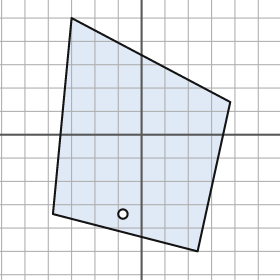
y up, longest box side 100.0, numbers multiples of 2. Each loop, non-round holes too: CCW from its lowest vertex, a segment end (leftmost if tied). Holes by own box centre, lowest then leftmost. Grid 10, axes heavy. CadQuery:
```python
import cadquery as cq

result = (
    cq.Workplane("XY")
    .moveTo(24.0, -50.0)
    .lineTo(38.0, 14.0)
    .lineTo(-30.0, 50.0)
    .lineTo(-38.0, -34.0)
    .close()
    .moveTo(-8.0, -34.0)
    .circle(2.0)
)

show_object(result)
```